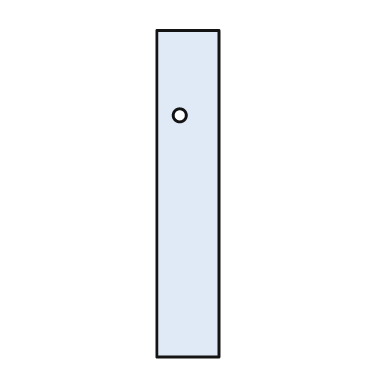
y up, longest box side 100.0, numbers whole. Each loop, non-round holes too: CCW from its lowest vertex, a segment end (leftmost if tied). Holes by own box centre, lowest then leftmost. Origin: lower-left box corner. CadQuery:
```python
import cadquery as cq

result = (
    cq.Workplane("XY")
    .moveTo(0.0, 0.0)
    .lineTo(19.0, 0.0)
    .lineTo(19.0, 100.0)
    .lineTo(0.0, 100.0)
    .close()
    .moveTo(7.0, 74.0)
    .circle(2.0)
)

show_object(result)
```